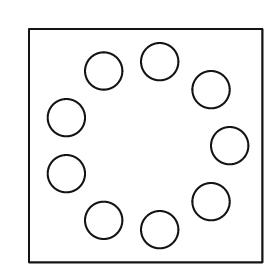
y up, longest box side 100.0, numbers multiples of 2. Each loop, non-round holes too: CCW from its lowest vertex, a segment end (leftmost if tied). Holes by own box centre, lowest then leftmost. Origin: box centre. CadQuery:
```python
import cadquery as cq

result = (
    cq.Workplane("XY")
    .moveTo(-50.0, -50.0)
    .lineTo(50.0, -50.0)
    .lineTo(50.0, 50.0)
    .lineTo(-50.0, 50.0)
    .close()
    .moveTo(6.0, -36.0)
    .circle(8.0)
    .moveTo(-18.0, -32.0)
    .circle(8.0)
    .moveTo(28.0, -24.0)
    .circle(8.0)
    .moveTo(-34.0, -12.0)
    .circle(8.0)
    .moveTo(36.0, 0.0)
    .circle(8.0)
    .moveTo(-34.0, 12.0)
    .circle(8.0)
    .moveTo(28.0, 24.0)
    .circle(8.0)
    .moveTo(-18.0, 32.0)
    .circle(8.0)
    .moveTo(6.0, 36.0)
    .circle(8.0)
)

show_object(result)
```